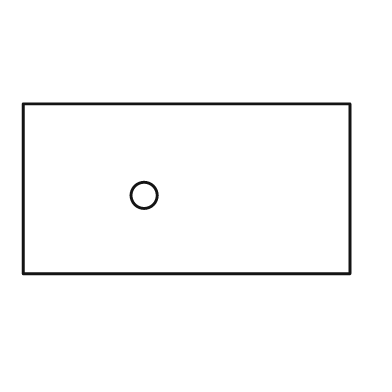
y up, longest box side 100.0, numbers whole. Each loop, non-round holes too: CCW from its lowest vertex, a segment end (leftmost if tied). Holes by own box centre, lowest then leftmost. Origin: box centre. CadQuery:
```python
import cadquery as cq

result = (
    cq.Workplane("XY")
    .moveTo(-50.0, -26.0)
    .lineTo(50.0, -26.0)
    .lineTo(50.0, 26.0)
    .lineTo(-50.0, 26.0)
    .close()
    .moveTo(-13.0, -2.0)
    .circle(4.0)
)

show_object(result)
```